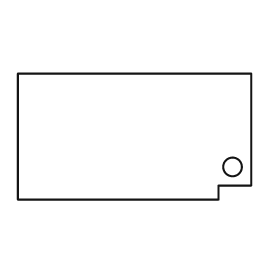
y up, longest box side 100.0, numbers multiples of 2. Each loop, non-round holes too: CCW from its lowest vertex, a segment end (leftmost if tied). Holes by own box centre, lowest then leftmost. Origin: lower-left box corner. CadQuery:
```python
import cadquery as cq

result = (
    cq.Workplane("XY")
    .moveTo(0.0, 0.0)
    .lineTo(86.0, 0.0)
    .lineTo(86.0, 6.0)
    .lineTo(100.0, 6.0)
    .lineTo(100.0, 54.0)
    .lineTo(0.0, 54.0)
    .close()
    .moveTo(92.0, 14.0)
    .circle(4.0)
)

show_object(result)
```